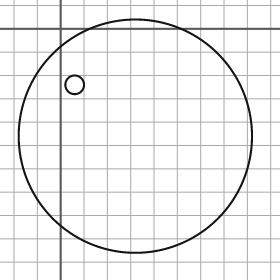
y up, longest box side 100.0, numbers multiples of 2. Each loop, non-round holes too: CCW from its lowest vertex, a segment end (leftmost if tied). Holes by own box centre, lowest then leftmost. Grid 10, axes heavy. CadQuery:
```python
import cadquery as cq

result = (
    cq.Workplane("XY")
    .moveTo(32.0, -46.0)
    .circle(50.0)
    .moveTo(6.0, -24.0)
    .circle(4.0)
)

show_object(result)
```